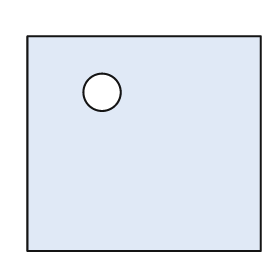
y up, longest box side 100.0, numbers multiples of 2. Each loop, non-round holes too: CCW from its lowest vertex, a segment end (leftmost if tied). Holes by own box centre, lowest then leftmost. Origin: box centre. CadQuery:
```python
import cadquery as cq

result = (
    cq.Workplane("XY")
    .moveTo(-50.0, -46.0)
    .lineTo(50.0, -46.0)
    .lineTo(50.0, 46.0)
    .lineTo(-50.0, 46.0)
    .close()
    .moveTo(-18.0, 22.0)
    .circle(8.0)
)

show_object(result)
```